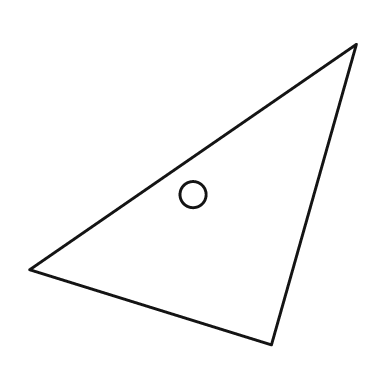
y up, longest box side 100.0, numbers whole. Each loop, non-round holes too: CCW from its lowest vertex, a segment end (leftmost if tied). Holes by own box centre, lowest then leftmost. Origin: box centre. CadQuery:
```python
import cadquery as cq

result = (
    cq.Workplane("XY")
    .moveTo(24.0, -46.0)
    .lineTo(50.0, 46.0)
    .lineTo(-50.0, -23.0)
    .close()
    .moveTo(0.0, 0.0)
    .circle(4.0)
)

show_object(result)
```